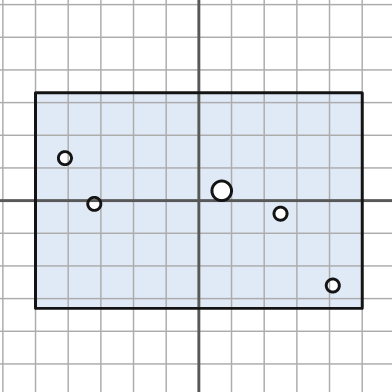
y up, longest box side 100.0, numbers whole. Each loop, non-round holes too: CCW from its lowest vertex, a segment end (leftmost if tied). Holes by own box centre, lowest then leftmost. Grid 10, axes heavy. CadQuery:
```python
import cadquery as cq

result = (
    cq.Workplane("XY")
    .moveTo(-50.0, -33.0)
    .lineTo(50.0, -33.0)
    .lineTo(50.0, 33.0)
    .lineTo(-50.0, 33.0)
    .close()
    .moveTo(41.0, -26.0)
    .circle(2.0)
    .moveTo(25.0, -4.0)
    .circle(2.0)
    .moveTo(-32.0, -1.0)
    .circle(2.0)
    .moveTo(7.0, 3.0)
    .circle(3.0)
    .moveTo(-41.0, 13.0)
    .circle(2.0)
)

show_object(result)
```